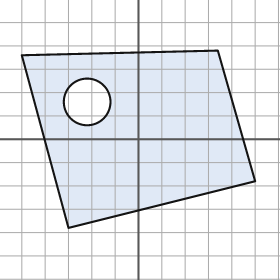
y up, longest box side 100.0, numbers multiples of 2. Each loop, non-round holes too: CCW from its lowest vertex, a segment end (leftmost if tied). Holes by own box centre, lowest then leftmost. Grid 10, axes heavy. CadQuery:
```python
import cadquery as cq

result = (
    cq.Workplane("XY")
    .moveTo(-30.0, -38.0)
    .lineTo(50.0, -18.0)
    .lineTo(34.0, 38.0)
    .lineTo(-50.0, 36.0)
    .close()
    .moveTo(-22.0, 16.0)
    .circle(10.0)
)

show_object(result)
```